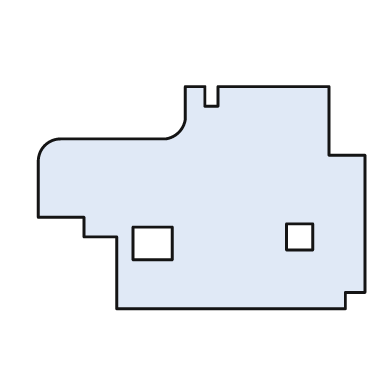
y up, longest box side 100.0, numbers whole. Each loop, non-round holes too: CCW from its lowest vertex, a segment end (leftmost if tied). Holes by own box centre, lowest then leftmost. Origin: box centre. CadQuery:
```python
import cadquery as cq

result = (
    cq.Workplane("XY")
    .moveTo(-26.0, -34.0)
    .lineTo(44.0, -34.0)
    .lineTo(44.0, -29.0)
    .lineTo(50.0, -29.0)
    .lineTo(50.0, 13.0)
    .lineTo(39.0, 13.0)
    .lineTo(39.0, 34.0)
    .lineTo(5.0, 34.0)
    .lineTo(5.0, 28.0)
    .lineTo(1.0, 28.0)
    .lineTo(1.0, 34.0)
    .lineTo(-5.0, 34.0)
    .lineTo(-5.0, 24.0)
    .threePointArc((-7.0, 20.0), (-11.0, 18.0))
    .lineTo(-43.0, 18.0)
    .threePointArc((-48.0, 16.0), (-50.0, 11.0))
    .lineTo(-50.0, -6.0)
    .lineTo(-36.0, -6.0)
    .lineTo(-36.0, -12.0)
    .lineTo(-26.0, -12.0)
    .close()
    .moveTo(-21.0, -19.0)
    .lineTo(-9.0, -19.0)
    .lineTo(-9.0, -9.0)
    .lineTo(-21.0, -9.0)
    .close()
    .moveTo(26.0, -16.0)
    .lineTo(34.0, -16.0)
    .lineTo(34.0, -8.0)
    .lineTo(26.0, -8.0)
    .close()
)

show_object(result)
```